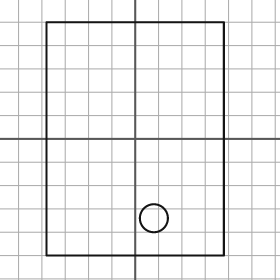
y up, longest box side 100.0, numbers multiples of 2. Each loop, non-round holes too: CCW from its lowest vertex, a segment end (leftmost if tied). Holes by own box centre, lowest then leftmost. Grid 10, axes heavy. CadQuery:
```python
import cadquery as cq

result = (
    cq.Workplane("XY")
    .moveTo(-38.0, -50.0)
    .lineTo(38.0, -50.0)
    .lineTo(38.0, 50.0)
    .lineTo(-38.0, 50.0)
    .close()
    .moveTo(8.0, -34.0)
    .circle(6.0)
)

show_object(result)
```